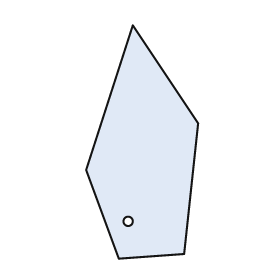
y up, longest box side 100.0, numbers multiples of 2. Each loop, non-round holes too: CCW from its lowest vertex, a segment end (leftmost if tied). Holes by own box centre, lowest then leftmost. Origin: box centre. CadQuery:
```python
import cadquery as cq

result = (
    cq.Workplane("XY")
    .moveTo(-10.0, -50.0)
    .lineTo(18.0, -48.0)
    .lineTo(24.0, 8.0)
    .lineTo(-4.0, 50.0)
    .lineTo(-24.0, -12.0)
    .close()
    .moveTo(-6.0, -34.0)
    .circle(2.0)
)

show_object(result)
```